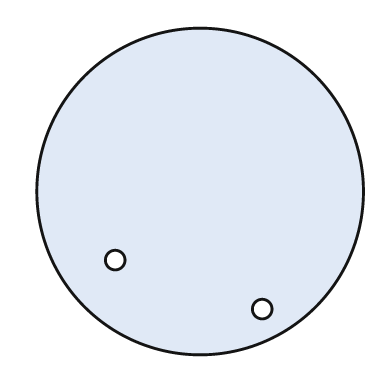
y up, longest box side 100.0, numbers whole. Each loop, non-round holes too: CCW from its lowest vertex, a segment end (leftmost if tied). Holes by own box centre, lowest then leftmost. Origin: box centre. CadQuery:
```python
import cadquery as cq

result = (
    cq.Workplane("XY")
    .moveTo(0.0, 0.0)
    .circle(50.0)
    .moveTo(19.0, -36.0)
    .circle(3.0)
    .moveTo(-26.0, -21.0)
    .circle(3.0)
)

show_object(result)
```